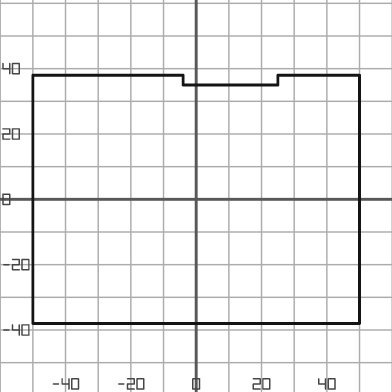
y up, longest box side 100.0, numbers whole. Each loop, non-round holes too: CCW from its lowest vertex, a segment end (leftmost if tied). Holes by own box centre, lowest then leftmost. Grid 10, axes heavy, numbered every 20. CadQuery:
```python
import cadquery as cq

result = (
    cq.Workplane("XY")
    .moveTo(-50.0, -38.0)
    .lineTo(50.0, -38.0)
    .lineTo(50.0, 38.0)
    .lineTo(25.0, 38.0)
    .lineTo(25.0, 35.0)
    .lineTo(-4.0, 35.0)
    .lineTo(-4.0, 38.0)
    .lineTo(-50.0, 38.0)
    .close()
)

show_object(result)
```